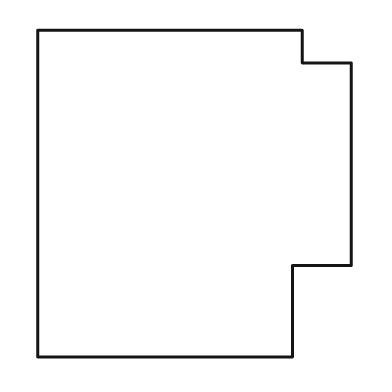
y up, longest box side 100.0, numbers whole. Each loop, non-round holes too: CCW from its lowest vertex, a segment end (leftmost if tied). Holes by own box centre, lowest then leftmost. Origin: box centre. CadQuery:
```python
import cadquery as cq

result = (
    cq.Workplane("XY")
    .moveTo(-48.0, -50.0)
    .lineTo(30.0, -50.0)
    .lineTo(30.0, -22.0)
    .lineTo(48.0, -22.0)
    .lineTo(48.0, 40.0)
    .lineTo(33.0, 40.0)
    .lineTo(33.0, 50.0)
    .lineTo(-48.0, 50.0)
    .close()
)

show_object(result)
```